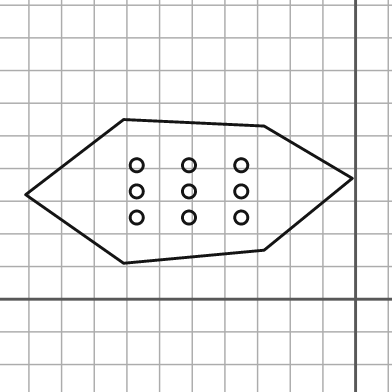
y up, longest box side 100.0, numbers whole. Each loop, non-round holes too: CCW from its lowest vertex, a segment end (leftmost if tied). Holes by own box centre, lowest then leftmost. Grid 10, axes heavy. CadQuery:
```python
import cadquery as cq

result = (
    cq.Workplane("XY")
    .moveTo(-71.0, 11.0)
    .lineTo(-28.0, 15.0)
    .lineTo(-1.0, 37.0)
    .lineTo(-28.0, 53.0)
    .lineTo(-71.0, 55.0)
    .lineTo(-101.0, 32.0)
    .close()
    .moveTo(-67.0, 25.0)
    .circle(2.0)
    .moveTo(-51.0, 25.0)
    .circle(2.0)
    .moveTo(-35.0, 25.0)
    .circle(2.0)
    .moveTo(-67.0, 33.0)
    .circle(2.0)
    .moveTo(-51.0, 33.0)
    .circle(2.0)
    .moveTo(-35.0, 33.0)
    .circle(2.0)
    .moveTo(-67.0, 41.0)
    .circle(2.0)
    .moveTo(-51.0, 41.0)
    .circle(2.0)
    .moveTo(-35.0, 41.0)
    .circle(2.0)
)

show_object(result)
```